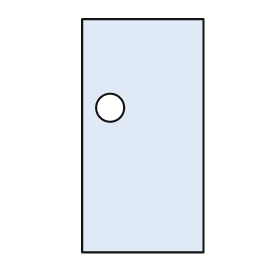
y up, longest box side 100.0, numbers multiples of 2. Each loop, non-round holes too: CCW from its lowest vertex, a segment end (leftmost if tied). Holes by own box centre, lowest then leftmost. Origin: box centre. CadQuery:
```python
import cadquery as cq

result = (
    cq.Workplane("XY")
    .moveTo(-26.0, -50.0)
    .lineTo(26.0, -50.0)
    .lineTo(26.0, 50.0)
    .lineTo(-26.0, 50.0)
    .close()
    .moveTo(-14.0, 12.0)
    .circle(6.0)
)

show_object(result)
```